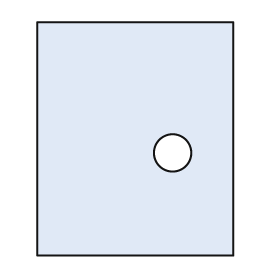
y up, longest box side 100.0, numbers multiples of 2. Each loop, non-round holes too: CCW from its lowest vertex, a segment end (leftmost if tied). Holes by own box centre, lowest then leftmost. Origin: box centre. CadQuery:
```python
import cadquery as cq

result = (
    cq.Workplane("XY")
    .moveTo(-42.0, -50.0)
    .lineTo(42.0, -50.0)
    .lineTo(42.0, 50.0)
    .lineTo(-42.0, 50.0)
    .close()
    .moveTo(16.0, -6.0)
    .circle(8.0)
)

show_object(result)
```